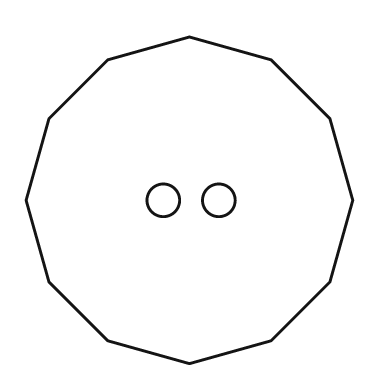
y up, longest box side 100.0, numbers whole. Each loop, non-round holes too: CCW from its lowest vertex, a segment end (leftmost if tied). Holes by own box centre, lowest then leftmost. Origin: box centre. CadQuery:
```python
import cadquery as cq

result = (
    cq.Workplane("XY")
    .moveTo(0.0, -50.0)
    .lineTo(25.0, -43.0)
    .lineTo(43.0, -25.0)
    .lineTo(50.0, 0.0)
    .lineTo(43.0, 25.0)
    .lineTo(25.0, 43.0)
    .lineTo(0.0, 50.0)
    .lineTo(-25.0, 43.0)
    .lineTo(-43.0, 25.0)
    .lineTo(-50.0, 0.0)
    .lineTo(-43.0, -25.0)
    .lineTo(-25.0, -43.0)
    .close()
    .moveTo(-8.0, 0.0)
    .circle(5.0)
    .moveTo(9.0, 0.0)
    .circle(5.0)
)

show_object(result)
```